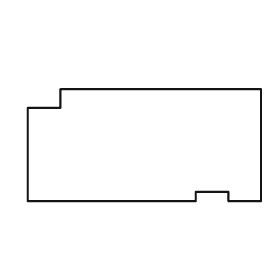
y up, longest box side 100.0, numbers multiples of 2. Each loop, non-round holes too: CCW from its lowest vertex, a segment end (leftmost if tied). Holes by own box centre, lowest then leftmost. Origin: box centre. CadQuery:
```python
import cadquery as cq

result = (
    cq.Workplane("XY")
    .moveTo(-50.0, -24.0)
    .lineTo(22.0, -24.0)
    .lineTo(22.0, -20.0)
    .lineTo(36.0, -20.0)
    .lineTo(36.0, -24.0)
    .lineTo(50.0, -24.0)
    .lineTo(50.0, 24.0)
    .lineTo(-36.0, 24.0)
    .lineTo(-36.0, 16.0)
    .lineTo(-50.0, 16.0)
    .close()
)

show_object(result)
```